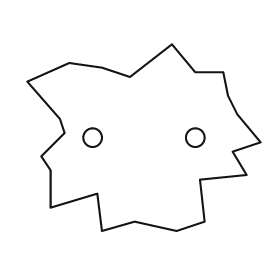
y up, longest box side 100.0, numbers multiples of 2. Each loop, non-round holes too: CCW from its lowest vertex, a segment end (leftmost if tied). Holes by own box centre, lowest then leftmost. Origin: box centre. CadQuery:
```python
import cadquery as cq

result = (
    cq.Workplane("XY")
    .moveTo(-18.0, -40.0)
    .lineTo(-4.0, -36.0)
    .lineTo(14.0, -40.0)
    .lineTo(26.0, -36.0)
    .lineTo(24.0, -18.0)
    .lineTo(44.0, -16.0)
    .lineTo(38.0, -6.0)
    .lineTo(50.0, -2.0)
    .lineTo(40.0, 10.0)
    .lineTo(36.0, 18.0)
    .lineTo(34.0, 28.0)
    .lineTo(22.0, 28.0)
    .lineTo(12.0, 40.0)
    .lineTo(-6.0, 26.0)
    .lineTo(-18.0, 30.0)
    .lineTo(-32.0, 32.0)
    .lineTo(-50.0, 24.0)
    .lineTo(-36.0, 8.0)
    .lineTo(-34.0, 2.0)
    .lineTo(-44.0, -8.0)
    .lineTo(-40.0, -14.0)
    .lineTo(-40.0, -30.0)
    .lineTo(-20.0, -24.0)
    .close()
    .moveTo(-22.0, 0.0)
    .circle(4.0)
    .moveTo(22.0, 0.0)
    .circle(4.0)
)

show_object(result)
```